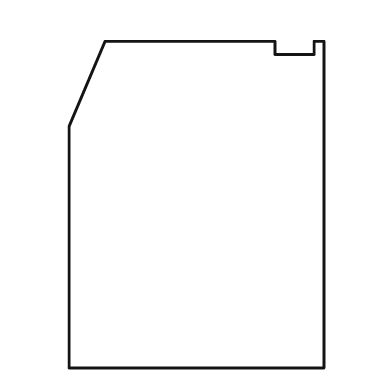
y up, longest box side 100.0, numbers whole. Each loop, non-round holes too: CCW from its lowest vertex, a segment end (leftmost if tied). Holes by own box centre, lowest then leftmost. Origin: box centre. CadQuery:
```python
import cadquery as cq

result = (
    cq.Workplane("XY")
    .moveTo(-39.0, -50.0)
    .lineTo(39.0, -50.0)
    .lineTo(39.0, 50.0)
    .lineTo(36.0, 50.0)
    .lineTo(36.0, 46.0)
    .lineTo(24.0, 46.0)
    .lineTo(24.0, 50.0)
    .lineTo(-28.0, 50.0)
    .lineTo(-39.0, 24.0)
    .close()
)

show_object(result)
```